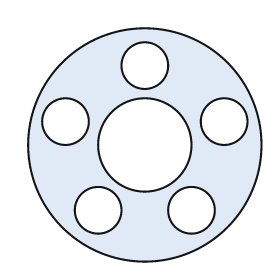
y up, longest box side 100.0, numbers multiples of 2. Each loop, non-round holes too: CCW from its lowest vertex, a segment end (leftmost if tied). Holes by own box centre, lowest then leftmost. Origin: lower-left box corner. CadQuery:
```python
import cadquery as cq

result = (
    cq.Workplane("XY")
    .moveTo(50.0, 50.0)
    .circle(50.0)
    .moveTo(30.0, 22.0)
    .circle(10.0)
    .moveTo(70.0, 22.0)
    .circle(10.0)
    .moveTo(50.0, 50.0)
    .circle(20.0)
    .moveTo(16.0, 60.0)
    .circle(10.0)
    .moveTo(84.0, 60.0)
    .circle(10.0)
    .moveTo(50.0, 84.0)
    .circle(10.0)
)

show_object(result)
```